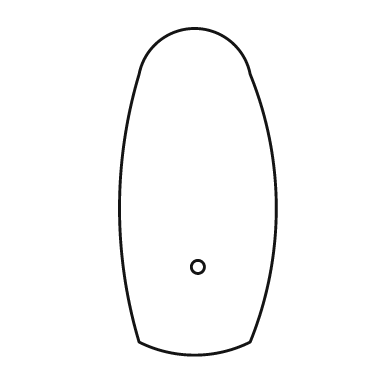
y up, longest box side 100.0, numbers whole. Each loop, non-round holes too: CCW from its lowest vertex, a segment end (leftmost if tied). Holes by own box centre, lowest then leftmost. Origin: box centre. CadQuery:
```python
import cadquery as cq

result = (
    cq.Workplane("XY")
    .moveTo(-18.0, -46.0)
    .threePointArc((-1.0, -50.0), (16.0, -46.0))
    .threePointArc((24.0, -5.0), (16.0, 36.0))
    .threePointArc((-1.0, 50.0), (-18.0, 36.0))
    .threePointArc((-24.0, -5.0), (-18.0, -46.0))
    .close()
    .moveTo(0.0, -23.0)
    .circle(2.0)
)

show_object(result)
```